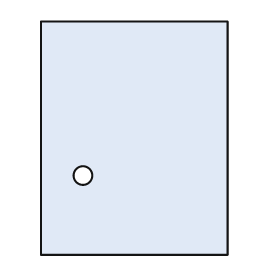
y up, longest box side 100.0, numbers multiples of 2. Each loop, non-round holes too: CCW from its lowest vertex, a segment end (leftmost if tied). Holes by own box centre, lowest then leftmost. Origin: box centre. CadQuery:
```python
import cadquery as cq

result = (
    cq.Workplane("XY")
    .moveTo(-40.0, -50.0)
    .lineTo(40.0, -50.0)
    .lineTo(40.0, 50.0)
    .lineTo(-40.0, 50.0)
    .close()
    .moveTo(-22.0, -16.0)
    .circle(4.0)
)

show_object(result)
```